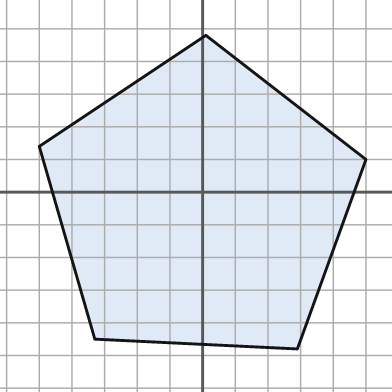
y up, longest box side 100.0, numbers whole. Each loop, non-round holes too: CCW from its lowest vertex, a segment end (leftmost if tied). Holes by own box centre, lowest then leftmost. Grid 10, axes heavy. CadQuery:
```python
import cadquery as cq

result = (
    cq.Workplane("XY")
    .moveTo(29.0, -48.0)
    .lineTo(50.0, 10.0)
    .lineTo(1.0, 48.0)
    .lineTo(-50.0, 14.0)
    .lineTo(-33.0, -45.0)
    .close()
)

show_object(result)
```